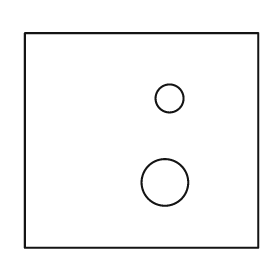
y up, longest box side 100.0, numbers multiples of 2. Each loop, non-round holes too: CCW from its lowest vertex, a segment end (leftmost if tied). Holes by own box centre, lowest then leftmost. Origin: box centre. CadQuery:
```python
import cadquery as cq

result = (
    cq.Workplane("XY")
    .moveTo(-50.0, -46.0)
    .lineTo(50.0, -46.0)
    .lineTo(50.0, 46.0)
    .lineTo(-50.0, 46.0)
    .close()
    .moveTo(10.0, -18.0)
    .circle(10.0)
    .moveTo(12.0, 18.0)
    .circle(6.0)
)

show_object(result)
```